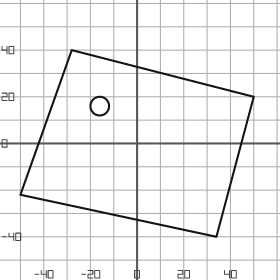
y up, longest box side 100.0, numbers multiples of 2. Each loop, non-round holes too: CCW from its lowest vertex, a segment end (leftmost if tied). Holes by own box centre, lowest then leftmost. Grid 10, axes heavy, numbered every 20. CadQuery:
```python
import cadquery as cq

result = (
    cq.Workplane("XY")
    .moveTo(34.0, -40.0)
    .lineTo(50.0, 20.0)
    .lineTo(-28.0, 40.0)
    .lineTo(-50.0, -22.0)
    .close()
    .moveTo(-16.0, 16.0)
    .circle(4.0)
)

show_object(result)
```